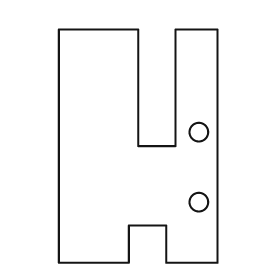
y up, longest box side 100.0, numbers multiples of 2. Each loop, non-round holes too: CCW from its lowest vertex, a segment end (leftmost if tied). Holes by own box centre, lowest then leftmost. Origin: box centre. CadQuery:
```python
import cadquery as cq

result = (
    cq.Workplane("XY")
    .moveTo(-34.0, -50.0)
    .lineTo(-4.0, -50.0)
    .lineTo(-4.0, -34.0)
    .lineTo(12.0, -34.0)
    .lineTo(12.0, -50.0)
    .lineTo(34.0, -50.0)
    .lineTo(34.0, 50.0)
    .lineTo(16.0, 50.0)
    .lineTo(16.0, 0.0)
    .lineTo(0.0, 0.0)
    .lineTo(0.0, 50.0)
    .lineTo(-34.0, 50.0)
    .close()
    .moveTo(26.0, -24.0)
    .circle(4.0)
    .moveTo(26.0, 6.0)
    .circle(4.0)
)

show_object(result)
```